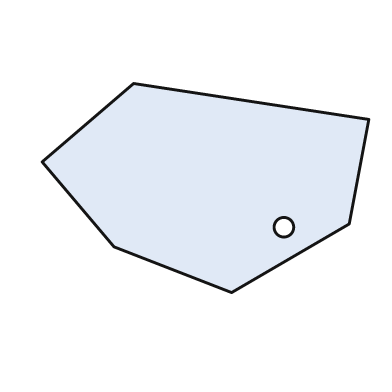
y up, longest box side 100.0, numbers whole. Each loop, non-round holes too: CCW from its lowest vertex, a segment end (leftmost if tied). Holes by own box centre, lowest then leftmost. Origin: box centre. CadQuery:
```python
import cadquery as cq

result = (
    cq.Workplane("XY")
    .moveTo(8.0, -32.0)
    .lineTo(44.0, -11.0)
    .lineTo(50.0, 21.0)
    .lineTo(-22.0, 32.0)
    .lineTo(-50.0, 8.0)
    .lineTo(-28.0, -18.0)
    .close()
    .moveTo(24.0, -12.0)
    .circle(3.0)
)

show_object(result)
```